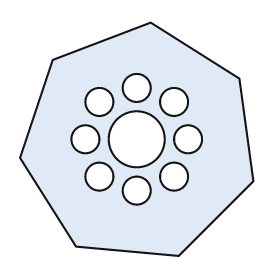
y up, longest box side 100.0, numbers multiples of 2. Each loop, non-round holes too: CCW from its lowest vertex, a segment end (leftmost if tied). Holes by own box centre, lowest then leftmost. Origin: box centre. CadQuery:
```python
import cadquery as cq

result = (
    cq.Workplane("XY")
    .moveTo(18.0, -50.0)
    .lineTo(50.0, -18.0)
    .lineTo(44.0, 26.0)
    .lineTo(6.0, 50.0)
    .lineTo(-36.0, 34.0)
    .lineTo(-50.0, -8.0)
    .lineTo(-26.0, -46.0)
    .close()
    .moveTo(0.0, -22.0)
    .circle(6.0)
    .moveTo(-16.0, -16.0)
    .circle(6.0)
    .moveTo(16.0, -16.0)
    .circle(6.0)
    .moveTo(-22.0, 0.0)
    .circle(6.0)
    .moveTo(0.0, 0.0)
    .circle(12.0)
    .moveTo(22.0, 0.0)
    .circle(6.0)
    .moveTo(-16.0, 16.0)
    .circle(6.0)
    .moveTo(16.0, 16.0)
    .circle(6.0)
    .moveTo(0.0, 22.0)
    .circle(6.0)
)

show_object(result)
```